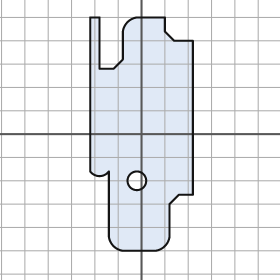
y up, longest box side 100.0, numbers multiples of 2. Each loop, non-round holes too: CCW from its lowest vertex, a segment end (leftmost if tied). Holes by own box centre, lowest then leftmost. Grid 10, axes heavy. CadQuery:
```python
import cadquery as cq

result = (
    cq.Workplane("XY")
    .moveTo(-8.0, -50.0)
    .lineTo(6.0, -50.0)
    .threePointArc((10.0, -48.0), (12.0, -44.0))
    .lineTo(12.0, -30.0)
    .lineTo(16.0, -26.0)
    .lineTo(22.0, -26.0)
    .lineTo(22.0, 40.0)
    .lineTo(14.0, 40.0)
    .lineTo(10.0, 44.0)
    .lineTo(10.0, 50.0)
    .lineTo(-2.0, 50.0)
    .threePointArc((-6.0, 48.0), (-8.0, 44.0))
    .lineTo(-8.0, 32.0)
    .lineTo(-12.0, 28.0)
    .lineTo(-18.0, 28.0)
    .lineTo(-18.0, 50.0)
    .lineTo(-22.0, 50.0)
    .lineTo(-22.0, -16.0)
    .threePointArc((-18.0, -18.0), (-14.0, -16.0))
    .lineTo(-14.0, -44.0)
    .threePointArc((-12.0, -48.0), (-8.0, -50.0))
    .close()
    .moveTo(-2.0, -20.0)
    .circle(4.0)
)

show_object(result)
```